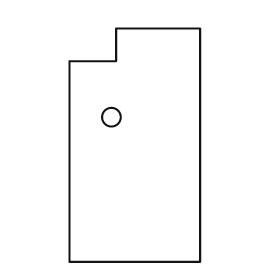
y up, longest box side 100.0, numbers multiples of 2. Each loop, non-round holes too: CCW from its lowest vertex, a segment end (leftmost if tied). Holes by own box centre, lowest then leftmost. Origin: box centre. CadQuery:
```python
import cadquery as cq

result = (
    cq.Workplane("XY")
    .moveTo(-28.0, -50.0)
    .lineTo(28.0, -50.0)
    .lineTo(28.0, 50.0)
    .lineTo(-8.0, 50.0)
    .lineTo(-8.0, 36.0)
    .lineTo(-28.0, 36.0)
    .close()
    .moveTo(-10.0, 12.0)
    .circle(4.0)
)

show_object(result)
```